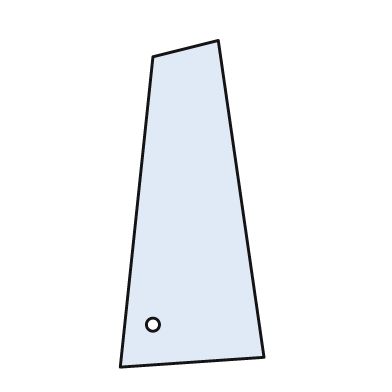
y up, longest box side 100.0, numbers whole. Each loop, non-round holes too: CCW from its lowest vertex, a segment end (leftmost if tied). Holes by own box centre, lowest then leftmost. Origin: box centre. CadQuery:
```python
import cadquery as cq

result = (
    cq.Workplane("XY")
    .moveTo(-22.0, -50.0)
    .lineTo(22.0, -47.0)
    .lineTo(8.0, 50.0)
    .lineTo(-12.0, 45.0)
    .close()
    .moveTo(-12.0, -37.0)
    .circle(2.0)
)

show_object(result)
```